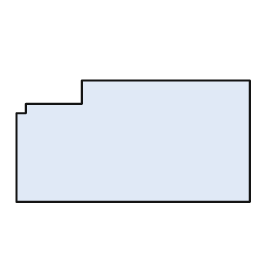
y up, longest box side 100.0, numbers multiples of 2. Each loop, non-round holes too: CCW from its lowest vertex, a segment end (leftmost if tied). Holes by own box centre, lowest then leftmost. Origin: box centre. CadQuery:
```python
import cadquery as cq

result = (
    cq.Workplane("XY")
    .moveTo(-50.0, -26.0)
    .lineTo(50.0, -26.0)
    .lineTo(50.0, 26.0)
    .lineTo(-22.0, 26.0)
    .lineTo(-22.0, 16.0)
    .lineTo(-46.0, 16.0)
    .lineTo(-46.0, 12.0)
    .lineTo(-50.0, 12.0)
    .close()
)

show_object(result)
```